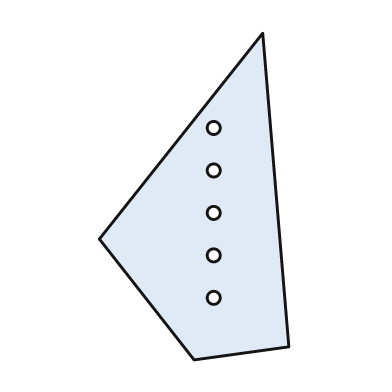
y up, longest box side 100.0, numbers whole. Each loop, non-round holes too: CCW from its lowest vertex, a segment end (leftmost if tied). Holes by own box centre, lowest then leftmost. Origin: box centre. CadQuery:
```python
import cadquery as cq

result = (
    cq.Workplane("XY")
    .moveTo(0.0, -50.0)
    .lineTo(29.0, -46.0)
    .lineTo(21.0, 50.0)
    .lineTo(-29.0, -13.0)
    .close()
    .moveTo(6.0, -31.0)
    .circle(2.0)
    .moveTo(6.0, -18.0)
    .circle(2.0)
    .moveTo(6.0, -5.0)
    .circle(2.0)
    .moveTo(6.0, 8.0)
    .circle(2.0)
    .moveTo(6.0, 21.0)
    .circle(2.0)
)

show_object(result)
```